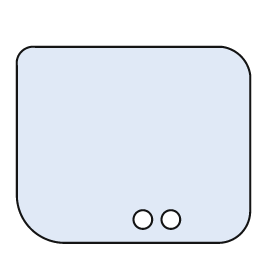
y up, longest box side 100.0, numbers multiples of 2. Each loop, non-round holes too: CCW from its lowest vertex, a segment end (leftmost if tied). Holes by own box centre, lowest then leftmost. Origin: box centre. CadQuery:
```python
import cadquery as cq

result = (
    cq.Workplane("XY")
    .moveTo(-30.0, -42.0)
    .lineTo(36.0, -42.0)
    .threePointArc((46.0, -38.0), (50.0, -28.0))
    .lineTo(50.0, 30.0)
    .threePointArc((46.0, 38.0), (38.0, 42.0))
    .lineTo(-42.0, 42.0)
    .threePointArc((-48.0, 40.0), (-50.0, 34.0))
    .lineTo(-50.0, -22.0)
    .threePointArc((-44.0, -36.0), (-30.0, -42.0))
    .close()
    .moveTo(4.0, -32.0)
    .circle(4.0)
    .moveTo(16.0, -32.0)
    .circle(4.0)
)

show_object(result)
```